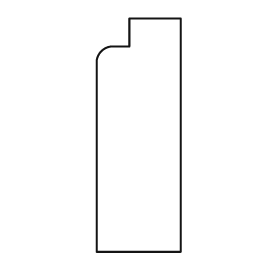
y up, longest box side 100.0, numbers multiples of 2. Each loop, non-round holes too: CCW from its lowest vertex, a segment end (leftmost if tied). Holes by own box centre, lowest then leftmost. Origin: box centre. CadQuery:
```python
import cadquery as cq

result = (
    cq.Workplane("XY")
    .moveTo(-18.0, -50.0)
    .lineTo(18.0, -50.0)
    .lineTo(18.0, 50.0)
    .lineTo(-4.0, 50.0)
    .lineTo(-4.0, 38.0)
    .lineTo(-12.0, 38.0)
    .threePointArc((-16.0, 36.0), (-18.0, 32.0))
    .close()
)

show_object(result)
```